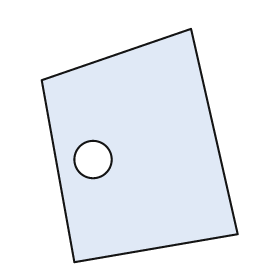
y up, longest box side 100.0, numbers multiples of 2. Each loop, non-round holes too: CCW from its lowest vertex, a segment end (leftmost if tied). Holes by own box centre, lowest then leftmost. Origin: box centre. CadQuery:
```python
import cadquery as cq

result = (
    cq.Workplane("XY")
    .moveTo(-28.0, -50.0)
    .lineTo(42.0, -38.0)
    .lineTo(22.0, 50.0)
    .lineTo(-42.0, 28.0)
    .close()
    .moveTo(-20.0, -6.0)
    .circle(8.0)
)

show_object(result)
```